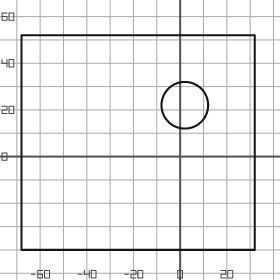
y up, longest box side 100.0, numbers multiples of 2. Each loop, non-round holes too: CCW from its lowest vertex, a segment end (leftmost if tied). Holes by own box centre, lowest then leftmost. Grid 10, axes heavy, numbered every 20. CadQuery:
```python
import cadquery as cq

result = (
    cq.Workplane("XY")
    .moveTo(-68.0, -40.0)
    .lineTo(32.0, -40.0)
    .lineTo(32.0, 52.0)
    .lineTo(-68.0, 52.0)
    .close()
    .moveTo(2.0, 22.0)
    .circle(10.0)
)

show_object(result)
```